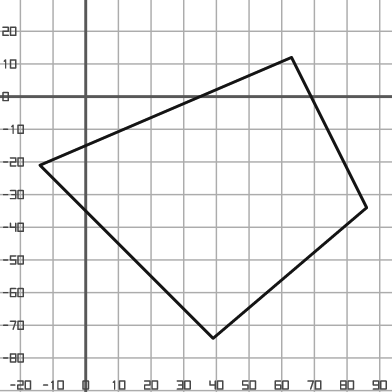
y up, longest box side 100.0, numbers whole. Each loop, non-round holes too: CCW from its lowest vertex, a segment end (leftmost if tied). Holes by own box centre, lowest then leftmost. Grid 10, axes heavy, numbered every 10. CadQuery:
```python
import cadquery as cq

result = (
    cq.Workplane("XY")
    .moveTo(39.0, -74.0)
    .lineTo(86.0, -34.0)
    .lineTo(63.0, 12.0)
    .lineTo(-14.0, -21.0)
    .close()
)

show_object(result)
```